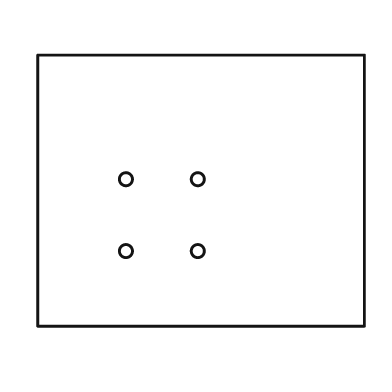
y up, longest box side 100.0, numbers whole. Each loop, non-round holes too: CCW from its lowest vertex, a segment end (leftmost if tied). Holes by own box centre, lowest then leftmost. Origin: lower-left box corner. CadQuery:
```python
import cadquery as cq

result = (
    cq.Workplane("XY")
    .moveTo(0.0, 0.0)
    .lineTo(100.0, 0.0)
    .lineTo(100.0, 83.0)
    .lineTo(0.0, 83.0)
    .close()
    .moveTo(27.0, 23.0)
    .circle(2.0)
    .moveTo(49.0, 23.0)
    .circle(2.0)
    .moveTo(27.0, 45.0)
    .circle(2.0)
    .moveTo(49.0, 45.0)
    .circle(2.0)
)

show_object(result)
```